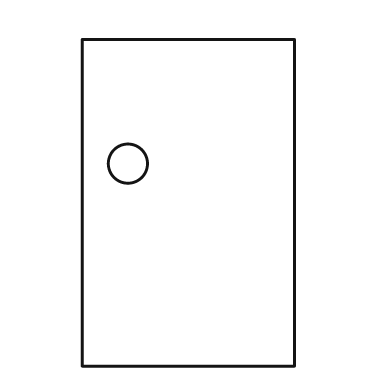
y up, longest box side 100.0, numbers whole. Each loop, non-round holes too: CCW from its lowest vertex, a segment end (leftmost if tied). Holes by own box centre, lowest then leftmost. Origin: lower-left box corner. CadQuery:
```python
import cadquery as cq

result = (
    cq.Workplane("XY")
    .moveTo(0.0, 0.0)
    .lineTo(65.0, 0.0)
    .lineTo(65.0, 100.0)
    .lineTo(0.0, 100.0)
    .close()
    .moveTo(14.0, 62.0)
    .circle(6.0)
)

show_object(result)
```